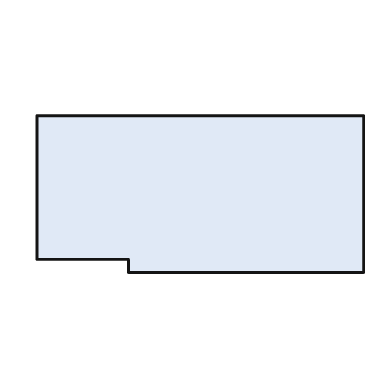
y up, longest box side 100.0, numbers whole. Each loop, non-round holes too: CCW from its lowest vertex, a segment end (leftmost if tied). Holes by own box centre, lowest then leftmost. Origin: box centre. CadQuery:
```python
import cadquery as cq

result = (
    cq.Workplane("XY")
    .moveTo(-22.0, -24.0)
    .lineTo(50.0, -24.0)
    .lineTo(50.0, 24.0)
    .lineTo(-50.0, 24.0)
    .lineTo(-50.0, -20.0)
    .lineTo(-22.0, -20.0)
    .close()
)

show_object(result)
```